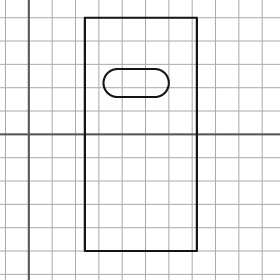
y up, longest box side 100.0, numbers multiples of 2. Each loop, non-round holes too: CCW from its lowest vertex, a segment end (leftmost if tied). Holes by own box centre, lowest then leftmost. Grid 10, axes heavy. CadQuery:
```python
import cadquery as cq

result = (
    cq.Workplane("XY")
    .moveTo(24.0, -50.0)
    .lineTo(72.0, -50.0)
    .lineTo(72.0, 50.0)
    .lineTo(24.0, 50.0)
    .close()
    .moveTo(38.0, 16.0)
    .lineTo(54.0, 16.0)
    .threePointArc((60.0, 22.0), (54.0, 28.0))
    .lineTo(38.0, 28.0)
    .threePointArc((32.0, 22.0), (38.0, 16.0))
    .close()
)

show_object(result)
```